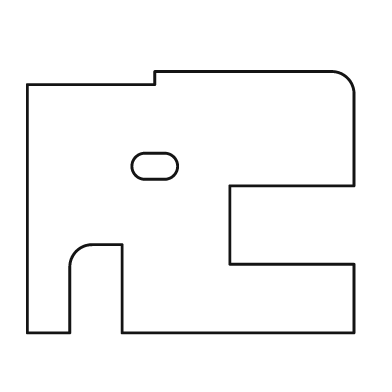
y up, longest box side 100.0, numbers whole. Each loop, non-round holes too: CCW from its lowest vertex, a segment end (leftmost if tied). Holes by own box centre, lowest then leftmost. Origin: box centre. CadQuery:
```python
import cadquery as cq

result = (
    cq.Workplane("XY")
    .moveTo(-50.0, -40.0)
    .lineTo(-37.0, -40.0)
    .lineTo(-37.0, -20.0)
    .threePointArc((-35.0, -15.0), (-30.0, -13.0))
    .lineTo(-21.0, -13.0)
    .lineTo(-21.0, -40.0)
    .lineTo(50.0, -40.0)
    .lineTo(50.0, -19.0)
    .lineTo(12.0, -19.0)
    .lineTo(12.0, 5.0)
    .lineTo(50.0, 5.0)
    .lineTo(50.0, 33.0)
    .threePointArc((48.0, 38.0), (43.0, 40.0))
    .lineTo(-11.0, 40.0)
    .lineTo(-11.0, 36.0)
    .lineTo(-50.0, 36.0)
    .close()
    .moveTo(-14.0, 7.0)
    .lineTo(-8.0, 7.0)
    .threePointArc((-4.0, 11.0), (-8.0, 15.0))
    .lineTo(-14.0, 15.0)
    .threePointArc((-18.0, 11.0), (-14.0, 7.0))
    .close()
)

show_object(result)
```